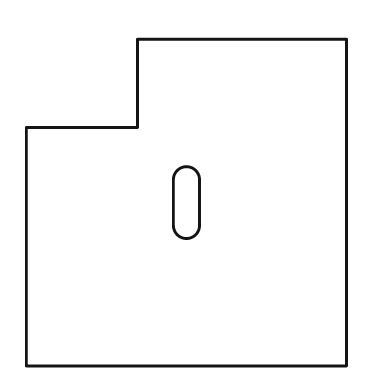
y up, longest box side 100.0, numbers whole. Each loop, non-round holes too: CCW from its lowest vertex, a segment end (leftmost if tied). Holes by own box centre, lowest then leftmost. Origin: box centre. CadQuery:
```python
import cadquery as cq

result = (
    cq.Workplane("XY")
    .moveTo(-49.0, -50.0)
    .lineTo(49.0, -50.0)
    .lineTo(49.0, 50.0)
    .lineTo(-15.0, 50.0)
    .lineTo(-15.0, 23.0)
    .lineTo(-49.0, 23.0)
    .close()
    .moveTo(-4.0, -7.0)
    .threePointArc((0.0, -11.0), (4.0, -7.0))
    .lineTo(4.0, 7.0)
    .threePointArc((0.0, 11.0), (-4.0, 7.0))
    .close()
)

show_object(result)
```